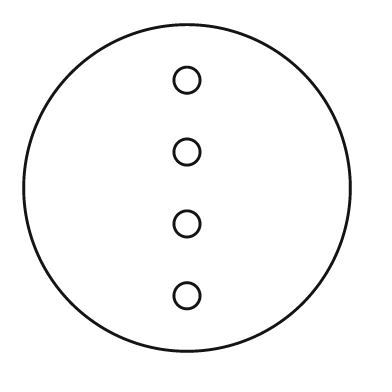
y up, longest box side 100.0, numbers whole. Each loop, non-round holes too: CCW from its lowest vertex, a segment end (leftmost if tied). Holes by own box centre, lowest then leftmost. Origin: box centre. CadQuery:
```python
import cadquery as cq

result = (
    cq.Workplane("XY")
    .moveTo(0.0, 0.0)
    .circle(50.0)
    .moveTo(0.0, -33.0)
    .circle(4.0)
    .moveTo(0.0, -11.0)
    .circle(4.0)
    .moveTo(0.0, 11.0)
    .circle(4.0)
    .moveTo(0.0, 33.0)
    .circle(4.0)
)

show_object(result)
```